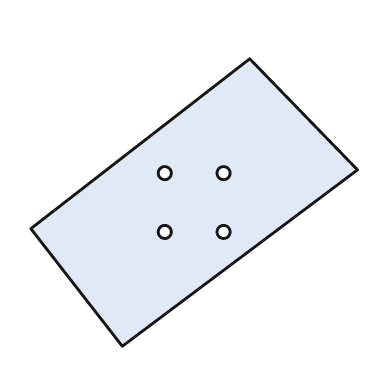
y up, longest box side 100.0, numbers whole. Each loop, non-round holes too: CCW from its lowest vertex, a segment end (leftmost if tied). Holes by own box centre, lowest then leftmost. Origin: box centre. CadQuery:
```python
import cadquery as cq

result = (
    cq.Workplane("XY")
    .moveTo(-22.0, -44.0)
    .lineTo(50.0, 10.0)
    .lineTo(17.0, 44.0)
    .lineTo(-50.0, -8.0)
    .close()
    .moveTo(-9.0, -9.0)
    .circle(2.0)
    .moveTo(9.0, -9.0)
    .circle(2.0)
    .moveTo(-9.0, 9.0)
    .circle(2.0)
    .moveTo(9.0, 9.0)
    .circle(2.0)
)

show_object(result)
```